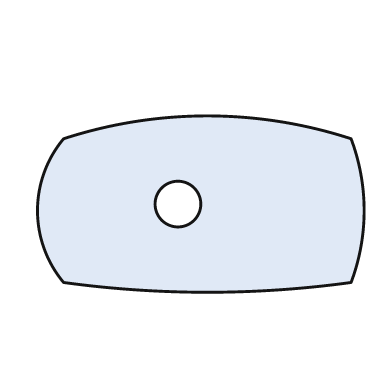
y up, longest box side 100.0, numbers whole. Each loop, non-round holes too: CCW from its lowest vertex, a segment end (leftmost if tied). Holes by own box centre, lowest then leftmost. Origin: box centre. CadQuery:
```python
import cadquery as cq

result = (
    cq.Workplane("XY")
    .moveTo(-42.0, -24.0)
    .threePointArc((2.0, -27.0), (46.0, -24.0))
    .threePointArc((50.0, -2.0), (46.0, 20.0))
    .threePointArc((2.0, 27.0), (-42.0, 20.0))
    .threePointArc((-50.0, -2.0), (-42.0, -24.0))
    .close()
    .moveTo(-7.0, 0.0)
    .circle(7.0)
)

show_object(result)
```